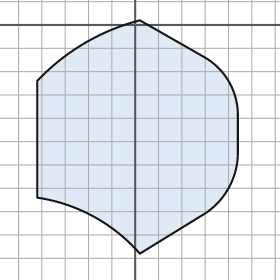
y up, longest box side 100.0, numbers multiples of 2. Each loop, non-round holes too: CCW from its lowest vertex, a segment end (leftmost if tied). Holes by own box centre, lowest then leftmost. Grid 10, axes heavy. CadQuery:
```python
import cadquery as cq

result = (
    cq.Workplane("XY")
    .moveTo(2.0, -98.0)
    .lineTo(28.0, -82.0)
    .threePointArc((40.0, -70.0), (44.0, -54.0))
    .lineTo(44.0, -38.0)
    .threePointArc((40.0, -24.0), (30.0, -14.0))
    .lineTo(2.0, 2.0)
    .threePointArc((-22.0, -8.0), (-42.0, -24.0))
    .lineTo(-42.0, -74.0)
    .threePointArc((-18.0, -82.0), (2.0, -98.0))
    .close()
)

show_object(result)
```